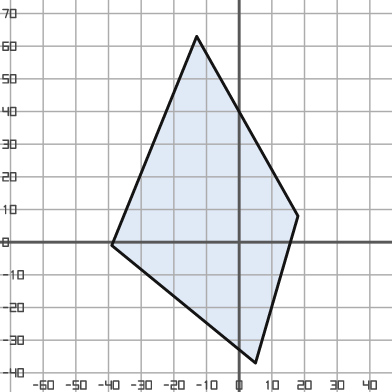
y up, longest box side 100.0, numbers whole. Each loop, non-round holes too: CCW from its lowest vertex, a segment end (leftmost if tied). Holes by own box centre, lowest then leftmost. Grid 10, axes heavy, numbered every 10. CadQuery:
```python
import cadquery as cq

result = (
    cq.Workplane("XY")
    .moveTo(5.0, -37.0)
    .lineTo(18.0, 8.0)
    .lineTo(-13.0, 63.0)
    .lineTo(-39.0, -1.0)
    .close()
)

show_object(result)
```